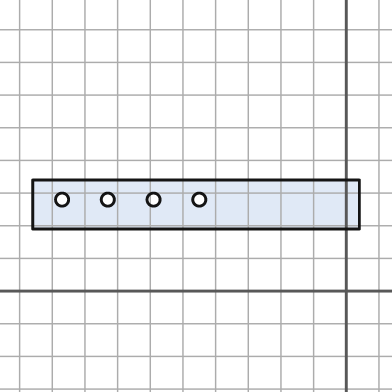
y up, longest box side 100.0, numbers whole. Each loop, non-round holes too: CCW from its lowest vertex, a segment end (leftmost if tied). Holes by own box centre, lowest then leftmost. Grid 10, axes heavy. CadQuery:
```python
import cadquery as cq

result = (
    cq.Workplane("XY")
    .moveTo(-96.0, 19.0)
    .lineTo(4.0, 19.0)
    .lineTo(4.0, 34.0)
    .lineTo(-96.0, 34.0)
    .close()
    .moveTo(-87.0, 28.0)
    .circle(2.0)
    .moveTo(-73.0, 28.0)
    .circle(2.0)
    .moveTo(-59.0, 28.0)
    .circle(2.0)
    .moveTo(-45.0, 28.0)
    .circle(2.0)
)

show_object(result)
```